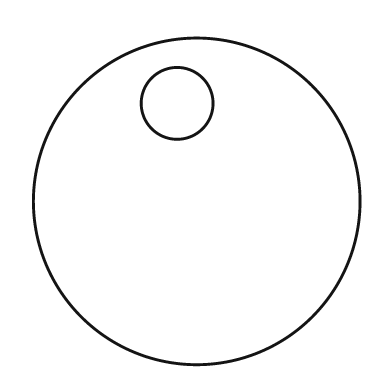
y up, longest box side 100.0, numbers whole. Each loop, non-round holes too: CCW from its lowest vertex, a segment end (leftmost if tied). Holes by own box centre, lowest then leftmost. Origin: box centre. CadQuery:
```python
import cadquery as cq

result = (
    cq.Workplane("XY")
    .moveTo(0.0, 0.0)
    .circle(50.0)
    .moveTo(-6.0, 30.0)
    .circle(11.0)
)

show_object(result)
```